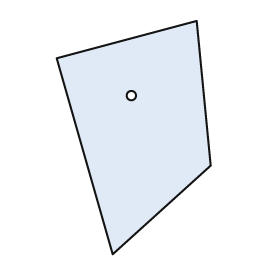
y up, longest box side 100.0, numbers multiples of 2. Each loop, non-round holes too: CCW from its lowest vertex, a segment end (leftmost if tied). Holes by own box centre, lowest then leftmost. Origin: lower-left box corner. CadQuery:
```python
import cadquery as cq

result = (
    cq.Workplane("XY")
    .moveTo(24.0, 0.0)
    .lineTo(66.0, 38.0)
    .lineTo(60.0, 100.0)
    .lineTo(0.0, 84.0)
    .close()
    .moveTo(32.0, 68.0)
    .circle(2.0)
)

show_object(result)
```